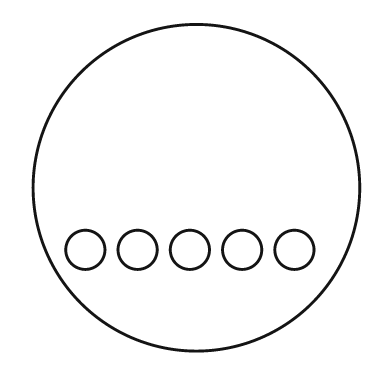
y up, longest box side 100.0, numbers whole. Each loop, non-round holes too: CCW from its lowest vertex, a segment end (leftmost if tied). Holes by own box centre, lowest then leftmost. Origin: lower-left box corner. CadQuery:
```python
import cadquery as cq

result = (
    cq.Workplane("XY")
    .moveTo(50.0, 50.0)
    .circle(50.0)
    .moveTo(16.0, 31.0)
    .circle(6.0)
    .moveTo(32.0, 31.0)
    .circle(6.0)
    .moveTo(48.0, 31.0)
    .circle(6.0)
    .moveTo(64.0, 31.0)
    .circle(6.0)
    .moveTo(80.0, 31.0)
    .circle(6.0)
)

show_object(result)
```